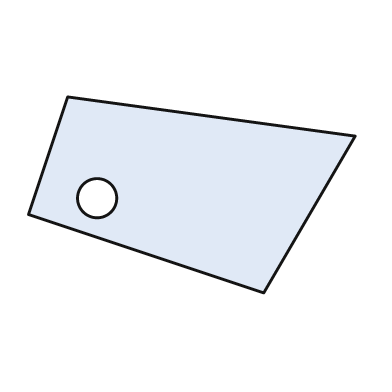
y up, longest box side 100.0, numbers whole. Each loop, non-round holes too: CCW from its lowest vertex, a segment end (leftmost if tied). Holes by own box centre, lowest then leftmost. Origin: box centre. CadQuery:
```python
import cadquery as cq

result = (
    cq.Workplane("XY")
    .moveTo(22.0, -30.0)
    .lineTo(50.0, 18.0)
    .lineTo(-38.0, 30.0)
    .lineTo(-50.0, -6.0)
    .close()
    .moveTo(-29.0, -1.0)
    .circle(6.0)
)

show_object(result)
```